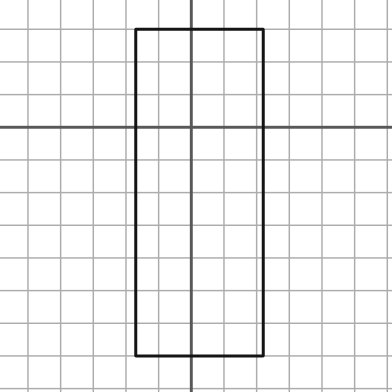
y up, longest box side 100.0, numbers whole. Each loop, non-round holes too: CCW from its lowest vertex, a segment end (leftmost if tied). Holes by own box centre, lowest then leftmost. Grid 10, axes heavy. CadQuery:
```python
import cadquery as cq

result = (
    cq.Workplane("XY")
    .moveTo(-17.0, -70.0)
    .lineTo(22.0, -70.0)
    .lineTo(22.0, 30.0)
    .lineTo(-17.0, 30.0)
    .close()
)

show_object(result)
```